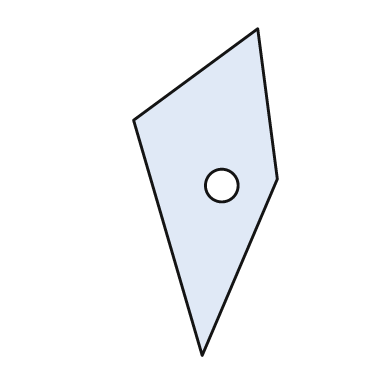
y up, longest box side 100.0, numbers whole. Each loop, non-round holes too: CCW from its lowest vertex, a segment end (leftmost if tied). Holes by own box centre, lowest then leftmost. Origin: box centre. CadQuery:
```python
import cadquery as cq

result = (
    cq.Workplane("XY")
    .moveTo(-1.0, -50.0)
    .lineTo(22.0, 4.0)
    .lineTo(16.0, 50.0)
    .lineTo(-22.0, 22.0)
    .close()
    .moveTo(5.0, 2.0)
    .circle(5.0)
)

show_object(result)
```